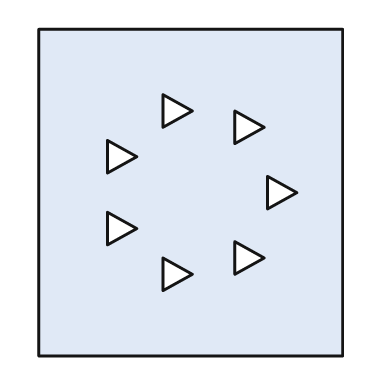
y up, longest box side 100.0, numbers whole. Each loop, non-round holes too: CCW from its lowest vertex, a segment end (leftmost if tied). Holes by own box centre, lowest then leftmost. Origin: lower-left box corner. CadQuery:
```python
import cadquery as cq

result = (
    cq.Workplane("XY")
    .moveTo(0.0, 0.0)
    .lineTo(93.0, 0.0)
    .lineTo(93.0, 100.0)
    .lineTo(0.0, 100.0)
    .close()
    .moveTo(38.0, 20.0)
    .lineTo(47.0, 25.0)
    .lineTo(38.0, 30.0)
    .close()
    .moveTo(60.0, 25.0)
    .lineTo(69.0, 30.0)
    .lineTo(60.0, 35.0)
    .close()
    .moveTo(21.0, 34.0)
    .lineTo(30.0, 39.0)
    .lineTo(21.0, 44.0)
    .close()
    .moveTo(70.0, 45.0)
    .lineTo(79.0, 50.0)
    .lineTo(70.0, 55.0)
    .close()
    .moveTo(21.0, 56.0)
    .lineTo(30.0, 61.0)
    .lineTo(21.0, 66.0)
    .close()
    .moveTo(60.0, 65.0)
    .lineTo(69.0, 70.0)
    .lineTo(60.0, 75.0)
    .close()
    .moveTo(38.0, 70.0)
    .lineTo(47.0, 75.0)
    .lineTo(38.0, 80.0)
    .close()
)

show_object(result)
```